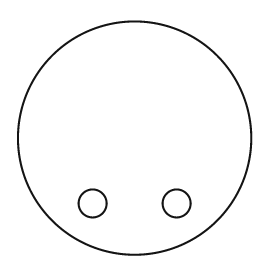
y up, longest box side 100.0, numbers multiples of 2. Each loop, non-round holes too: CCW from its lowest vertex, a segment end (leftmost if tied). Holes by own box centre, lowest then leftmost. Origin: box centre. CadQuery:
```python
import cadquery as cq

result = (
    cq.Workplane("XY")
    .moveTo(0.0, 0.0)
    .circle(50.0)
    .moveTo(-18.0, -28.0)
    .circle(6.0)
    .moveTo(18.0, -28.0)
    .circle(6.0)
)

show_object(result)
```